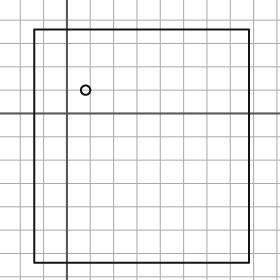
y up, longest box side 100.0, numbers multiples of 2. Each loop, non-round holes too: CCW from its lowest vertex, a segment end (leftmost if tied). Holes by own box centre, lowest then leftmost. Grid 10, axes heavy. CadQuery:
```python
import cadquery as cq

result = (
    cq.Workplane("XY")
    .moveTo(-14.0, -64.0)
    .lineTo(78.0, -64.0)
    .lineTo(78.0, 36.0)
    .lineTo(-14.0, 36.0)
    .close()
    .moveTo(8.0, 10.0)
    .circle(2.0)
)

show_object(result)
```